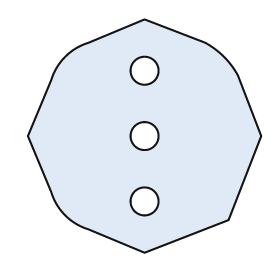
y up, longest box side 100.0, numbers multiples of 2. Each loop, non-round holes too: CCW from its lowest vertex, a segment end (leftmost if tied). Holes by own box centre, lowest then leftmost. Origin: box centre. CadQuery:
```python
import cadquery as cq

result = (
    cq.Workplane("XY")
    .moveTo(0.0, -50.0)
    .lineTo(36.0, -36.0)
    .lineTo(50.0, 0.0)
    .lineTo(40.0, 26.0)
    .threePointArc((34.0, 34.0), (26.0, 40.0))
    .lineTo(0.0, 50.0)
    .lineTo(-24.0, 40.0)
    .threePointArc((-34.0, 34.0), (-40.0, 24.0))
    .lineTo(-50.0, 0.0)
    .lineTo(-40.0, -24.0)
    .threePointArc((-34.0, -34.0), (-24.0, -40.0))
    .close()
    .moveTo(0.0, -28.0)
    .circle(6.0)
    .moveTo(0.0, 0.0)
    .circle(6.0)
    .moveTo(0.0, 28.0)
    .circle(6.0)
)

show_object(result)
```